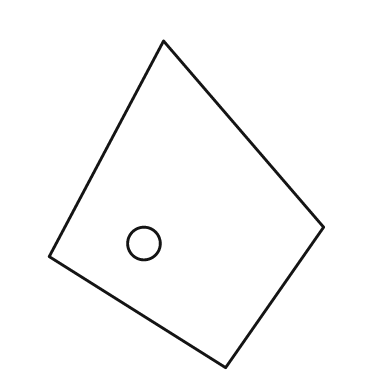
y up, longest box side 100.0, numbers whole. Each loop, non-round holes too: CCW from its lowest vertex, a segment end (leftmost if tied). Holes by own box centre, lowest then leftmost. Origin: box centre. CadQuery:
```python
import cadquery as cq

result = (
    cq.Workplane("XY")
    .moveTo(12.0, -50.0)
    .lineTo(42.0, -7.0)
    .lineTo(-7.0, 50.0)
    .lineTo(-42.0, -16.0)
    .close()
    .moveTo(-13.0, -12.0)
    .circle(5.0)
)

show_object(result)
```